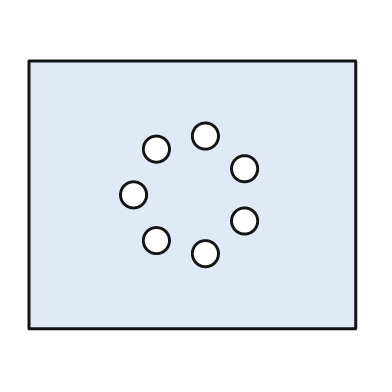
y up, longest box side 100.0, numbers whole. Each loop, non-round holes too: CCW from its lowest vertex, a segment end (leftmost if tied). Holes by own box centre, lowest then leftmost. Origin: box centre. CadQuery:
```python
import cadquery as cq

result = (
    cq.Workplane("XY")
    .moveTo(-50.0, -41.0)
    .lineTo(50.0, -41.0)
    .lineTo(50.0, 41.0)
    .lineTo(-50.0, 41.0)
    .close()
    .moveTo(4.0, -18.0)
    .circle(4.0)
    .moveTo(-11.0, -14.0)
    .circle(4.0)
    .moveTo(16.0, -8.0)
    .circle(4.0)
    .moveTo(-18.0, 0.0)
    .circle(4.0)
    .moveTo(16.0, 8.0)
    .circle(4.0)
    .moveTo(-11.0, 14.0)
    .circle(4.0)
    .moveTo(4.0, 18.0)
    .circle(4.0)
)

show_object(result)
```